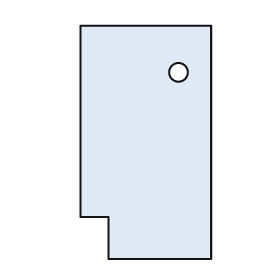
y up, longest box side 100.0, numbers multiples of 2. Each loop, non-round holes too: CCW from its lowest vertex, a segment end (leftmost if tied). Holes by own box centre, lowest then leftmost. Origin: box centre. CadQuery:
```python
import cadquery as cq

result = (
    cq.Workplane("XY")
    .moveTo(-16.0, -50.0)
    .lineTo(28.0, -50.0)
    .lineTo(28.0, 50.0)
    .lineTo(-28.0, 50.0)
    .lineTo(-28.0, -32.0)
    .lineTo(-16.0, -32.0)
    .close()
    .moveTo(14.0, 30.0)
    .circle(4.0)
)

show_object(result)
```